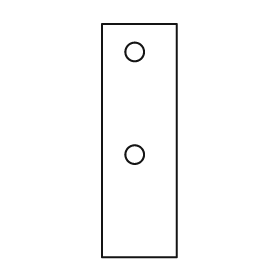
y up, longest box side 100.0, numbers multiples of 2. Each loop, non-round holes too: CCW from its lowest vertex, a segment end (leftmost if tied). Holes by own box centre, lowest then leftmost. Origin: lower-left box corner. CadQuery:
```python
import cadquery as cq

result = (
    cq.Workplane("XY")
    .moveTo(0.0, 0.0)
    .lineTo(32.0, 0.0)
    .lineTo(32.0, 100.0)
    .lineTo(0.0, 100.0)
    .close()
    .moveTo(14.0, 44.0)
    .circle(4.0)
    .moveTo(14.0, 88.0)
    .circle(4.0)
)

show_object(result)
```